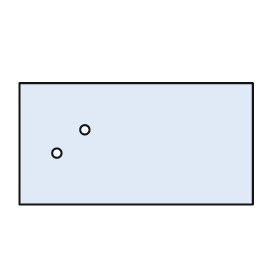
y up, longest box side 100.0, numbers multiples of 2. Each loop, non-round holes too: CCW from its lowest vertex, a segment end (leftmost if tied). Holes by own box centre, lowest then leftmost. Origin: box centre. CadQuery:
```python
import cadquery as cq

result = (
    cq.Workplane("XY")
    .moveTo(-50.0, -26.0)
    .lineTo(50.0, -26.0)
    .lineTo(50.0, 26.0)
    .lineTo(-50.0, 26.0)
    .close()
    .moveTo(-34.0, -4.0)
    .circle(2.0)
    .moveTo(-22.0, 6.0)
    .circle(2.0)
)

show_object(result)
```